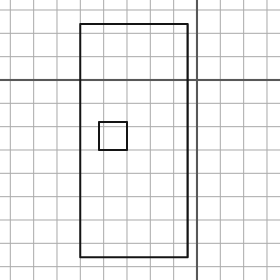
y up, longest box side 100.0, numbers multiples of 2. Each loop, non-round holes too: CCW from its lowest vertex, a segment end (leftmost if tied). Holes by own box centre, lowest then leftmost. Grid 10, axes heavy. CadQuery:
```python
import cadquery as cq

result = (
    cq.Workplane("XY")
    .moveTo(-50.0, -76.0)
    .lineTo(-4.0, -76.0)
    .lineTo(-4.0, 24.0)
    .lineTo(-50.0, 24.0)
    .close()
    .moveTo(-42.0, -30.0)
    .lineTo(-30.0, -30.0)
    .lineTo(-30.0, -18.0)
    .lineTo(-42.0, -18.0)
    .close()
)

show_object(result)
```